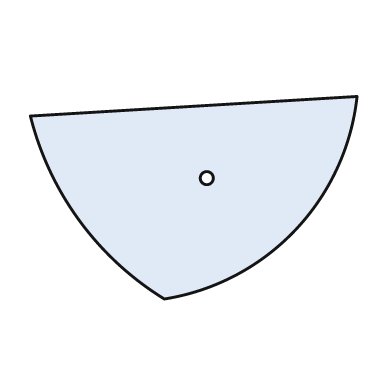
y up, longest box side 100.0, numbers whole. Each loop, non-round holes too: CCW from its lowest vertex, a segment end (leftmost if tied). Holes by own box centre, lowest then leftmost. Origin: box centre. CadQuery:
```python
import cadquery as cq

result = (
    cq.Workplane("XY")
    .moveTo(-9.0, -31.0)
    .threePointArc((31.0, -10.0), (50.0, 31.0))
    .lineTo(-50.0, 25.0)
    .threePointArc((-35.0, -7.0), (-9.0, -31.0))
    .close()
    .moveTo(4.0, 6.0)
    .circle(2.0)
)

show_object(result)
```